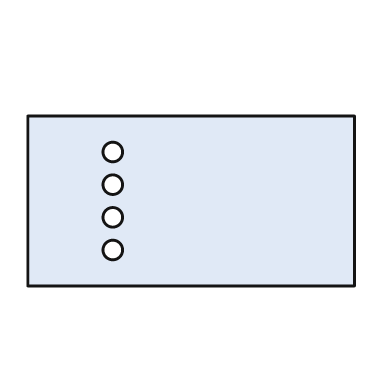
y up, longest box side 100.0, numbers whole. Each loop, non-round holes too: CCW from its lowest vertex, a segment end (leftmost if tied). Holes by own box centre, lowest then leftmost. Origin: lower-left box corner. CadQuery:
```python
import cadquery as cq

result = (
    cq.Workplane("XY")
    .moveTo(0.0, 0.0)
    .lineTo(100.0, 0.0)
    .lineTo(100.0, 52.0)
    .lineTo(0.0, 52.0)
    .close()
    .moveTo(26.0, 11.0)
    .circle(3.0)
    .moveTo(26.0, 21.0)
    .circle(3.0)
    .moveTo(26.0, 31.0)
    .circle(3.0)
    .moveTo(26.0, 41.0)
    .circle(3.0)
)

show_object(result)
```